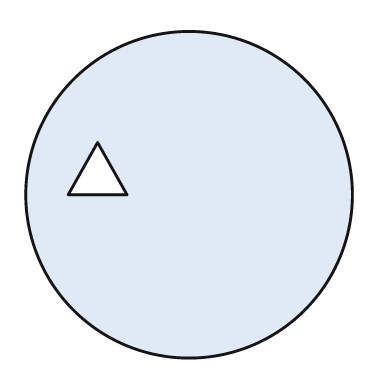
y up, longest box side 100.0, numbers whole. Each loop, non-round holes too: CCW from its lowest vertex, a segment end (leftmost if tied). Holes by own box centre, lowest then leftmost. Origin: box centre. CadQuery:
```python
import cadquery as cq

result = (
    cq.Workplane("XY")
    .moveTo(0.0, 0.0)
    .circle(50.0)
    .moveTo(-37.0, 0.0)
    .lineTo(-19.0, 0.0)
    .lineTo(-28.0, 16.0)
    .close()
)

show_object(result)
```